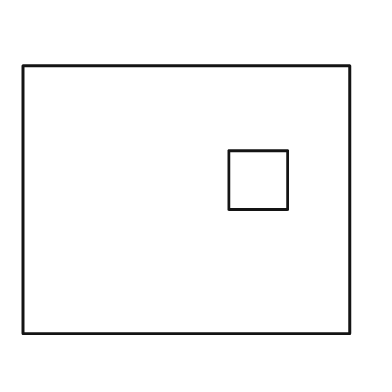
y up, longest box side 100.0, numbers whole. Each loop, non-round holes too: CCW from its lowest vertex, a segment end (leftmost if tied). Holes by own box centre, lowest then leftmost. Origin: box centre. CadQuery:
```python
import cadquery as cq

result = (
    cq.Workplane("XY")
    .moveTo(-50.0, -41.0)
    .lineTo(50.0, -41.0)
    .lineTo(50.0, 41.0)
    .lineTo(-50.0, 41.0)
    .close()
    .moveTo(13.0, -3.0)
    .lineTo(31.0, -3.0)
    .lineTo(31.0, 15.0)
    .lineTo(13.0, 15.0)
    .close()
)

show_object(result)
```